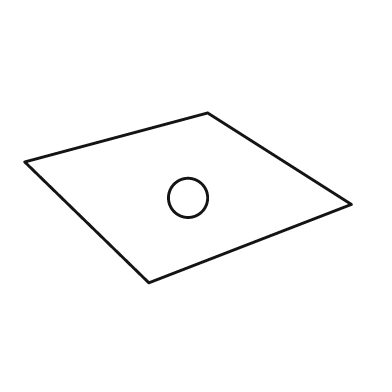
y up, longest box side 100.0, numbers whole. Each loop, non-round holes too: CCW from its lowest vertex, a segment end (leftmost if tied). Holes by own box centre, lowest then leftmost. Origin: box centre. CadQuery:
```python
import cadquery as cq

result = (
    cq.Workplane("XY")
    .moveTo(-12.0, -26.0)
    .lineTo(50.0, -2.0)
    .lineTo(6.0, 26.0)
    .lineTo(-50.0, 11.0)
    .close()
    .moveTo(0.0, 0.0)
    .circle(6.0)
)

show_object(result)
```